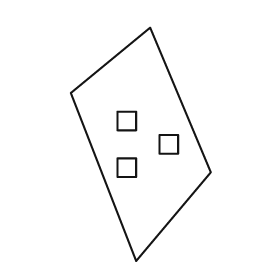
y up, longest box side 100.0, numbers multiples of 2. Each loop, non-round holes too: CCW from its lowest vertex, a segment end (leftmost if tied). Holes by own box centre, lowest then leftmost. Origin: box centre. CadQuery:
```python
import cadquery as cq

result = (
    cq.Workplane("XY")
    .moveTo(-2.0, -50.0)
    .lineTo(30.0, -12.0)
    .lineTo(4.0, 50.0)
    .lineTo(-30.0, 22.0)
    .close()
    .moveTo(-10.0, -14.0)
    .lineTo(-2.0, -14.0)
    .lineTo(-2.0, -6.0)
    .lineTo(-10.0, -6.0)
    .close()
    .moveTo(8.0, -4.0)
    .lineTo(16.0, -4.0)
    .lineTo(16.0, 4.0)
    .lineTo(8.0, 4.0)
    .close()
    .moveTo(-10.0, 6.0)
    .lineTo(-2.0, 6.0)
    .lineTo(-2.0, 14.0)
    .lineTo(-10.0, 14.0)
    .close()
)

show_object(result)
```